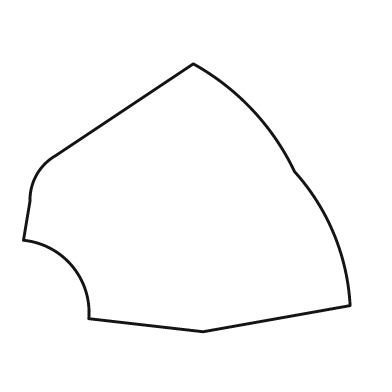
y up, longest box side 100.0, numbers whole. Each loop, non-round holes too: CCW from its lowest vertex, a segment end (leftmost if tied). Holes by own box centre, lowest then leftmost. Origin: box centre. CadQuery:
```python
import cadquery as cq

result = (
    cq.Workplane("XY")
    .moveTo(5.0, -41.0)
    .lineTo(50.0, -33.0)
    .threePointArc((45.0, -11.0), (33.0, 8.0))
    .threePointArc((20.0, 27.0), (2.0, 41.0))
    .lineTo(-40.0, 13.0)
    .threePointArc((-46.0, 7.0), (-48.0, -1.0))
    .lineTo(-50.0, -13.0)
    .threePointArc((-35.0, -21.0), (-30.0, -37.0))
    .close()
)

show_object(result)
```